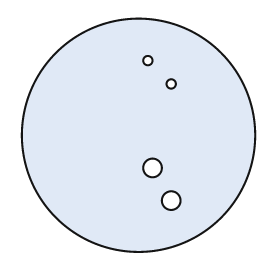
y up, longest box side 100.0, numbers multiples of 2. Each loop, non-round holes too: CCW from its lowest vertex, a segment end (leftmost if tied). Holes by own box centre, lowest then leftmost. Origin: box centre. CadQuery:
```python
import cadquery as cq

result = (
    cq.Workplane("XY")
    .moveTo(0.0, 0.0)
    .circle(50.0)
    .moveTo(14.0, -28.0)
    .circle(4.0)
    .moveTo(6.0, -14.0)
    .circle(4.0)
    .moveTo(14.0, 22.0)
    .circle(2.0)
    .moveTo(4.0, 32.0)
    .circle(2.0)
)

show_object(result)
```